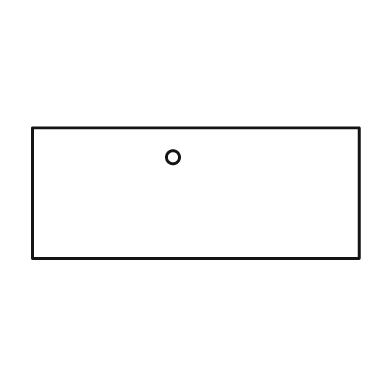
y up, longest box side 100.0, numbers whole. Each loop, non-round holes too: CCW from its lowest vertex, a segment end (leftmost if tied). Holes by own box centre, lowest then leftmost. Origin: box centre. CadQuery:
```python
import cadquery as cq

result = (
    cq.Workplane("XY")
    .moveTo(-50.0, -20.0)
    .lineTo(50.0, -20.0)
    .lineTo(50.0, 20.0)
    .lineTo(-50.0, 20.0)
    .close()
    .moveTo(-7.0, 11.0)
    .circle(2.0)
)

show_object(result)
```